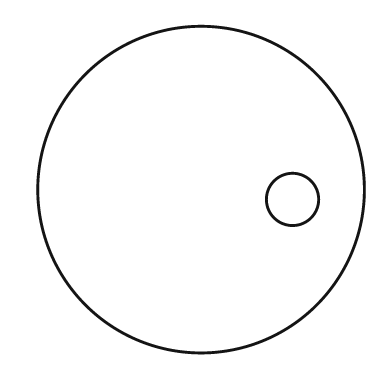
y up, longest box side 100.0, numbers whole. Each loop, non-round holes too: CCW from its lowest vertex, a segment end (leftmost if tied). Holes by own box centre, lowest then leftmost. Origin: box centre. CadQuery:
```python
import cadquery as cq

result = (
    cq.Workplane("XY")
    .moveTo(0.0, 0.0)
    .circle(50.0)
    .moveTo(28.0, -3.0)
    .circle(8.0)
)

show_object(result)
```